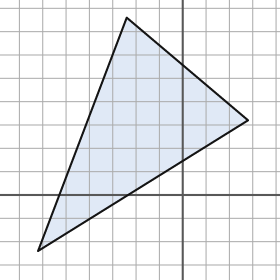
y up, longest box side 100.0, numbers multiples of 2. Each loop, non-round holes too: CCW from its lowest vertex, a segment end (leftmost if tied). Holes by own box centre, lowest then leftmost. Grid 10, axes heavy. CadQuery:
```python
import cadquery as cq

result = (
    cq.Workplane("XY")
    .moveTo(-62.0, -24.0)
    .lineTo(28.0, 32.0)
    .lineTo(-24.0, 76.0)
    .close()
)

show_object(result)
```